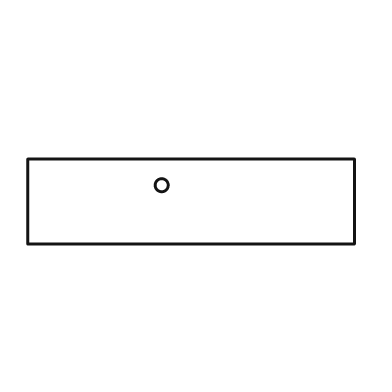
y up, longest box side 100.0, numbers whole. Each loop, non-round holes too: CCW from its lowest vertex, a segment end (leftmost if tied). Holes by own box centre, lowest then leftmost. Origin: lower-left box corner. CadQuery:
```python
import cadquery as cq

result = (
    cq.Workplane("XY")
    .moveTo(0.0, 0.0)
    .lineTo(100.0, 0.0)
    .lineTo(100.0, 26.0)
    .lineTo(0.0, 26.0)
    .close()
    .moveTo(41.0, 18.0)
    .circle(2.0)
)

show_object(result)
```